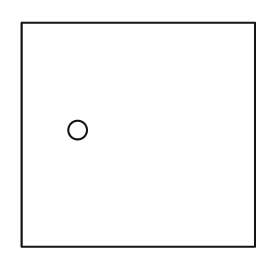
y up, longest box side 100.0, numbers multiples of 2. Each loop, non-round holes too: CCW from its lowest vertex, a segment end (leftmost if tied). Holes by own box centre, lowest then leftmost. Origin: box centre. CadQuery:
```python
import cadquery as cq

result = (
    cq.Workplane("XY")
    .moveTo(-50.0, -48.0)
    .lineTo(50.0, -48.0)
    .lineTo(50.0, 48.0)
    .lineTo(-50.0, 48.0)
    .close()
    .moveTo(-26.0, 2.0)
    .circle(4.0)
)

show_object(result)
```